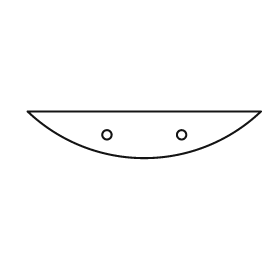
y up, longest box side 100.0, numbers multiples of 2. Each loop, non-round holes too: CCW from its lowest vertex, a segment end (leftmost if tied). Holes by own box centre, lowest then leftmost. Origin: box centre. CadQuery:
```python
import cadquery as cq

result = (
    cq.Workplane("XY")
    .moveTo(-50.0, 10.0)
    .threePointArc((0.0, -10.0), (50.0, 10.0))
    .close()
    .moveTo(-16.0, 0.0)
    .circle(2.0)
    .moveTo(16.0, 0.0)
    .circle(2.0)
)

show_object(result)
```